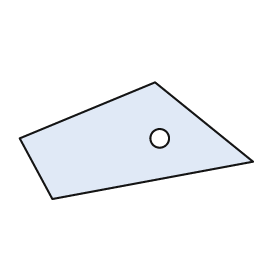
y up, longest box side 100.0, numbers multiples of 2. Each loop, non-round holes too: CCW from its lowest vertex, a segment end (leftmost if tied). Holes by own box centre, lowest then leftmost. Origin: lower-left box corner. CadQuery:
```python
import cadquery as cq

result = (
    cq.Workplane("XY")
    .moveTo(14.0, 0.0)
    .lineTo(100.0, 16.0)
    .lineTo(58.0, 50.0)
    .lineTo(0.0, 26.0)
    .close()
    .moveTo(60.0, 26.0)
    .circle(4.0)
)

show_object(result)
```